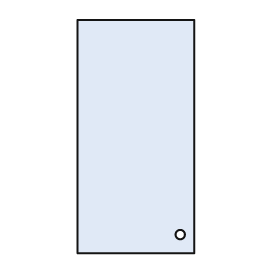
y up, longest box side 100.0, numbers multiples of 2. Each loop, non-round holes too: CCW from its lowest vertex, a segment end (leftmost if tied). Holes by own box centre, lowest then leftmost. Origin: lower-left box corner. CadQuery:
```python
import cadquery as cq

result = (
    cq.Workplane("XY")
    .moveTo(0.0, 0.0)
    .lineTo(50.0, 0.0)
    .lineTo(50.0, 100.0)
    .lineTo(0.0, 100.0)
    .close()
    .moveTo(44.0, 8.0)
    .circle(2.0)
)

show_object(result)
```